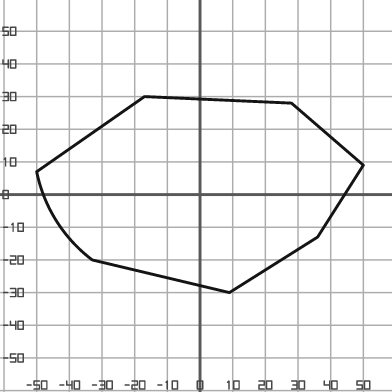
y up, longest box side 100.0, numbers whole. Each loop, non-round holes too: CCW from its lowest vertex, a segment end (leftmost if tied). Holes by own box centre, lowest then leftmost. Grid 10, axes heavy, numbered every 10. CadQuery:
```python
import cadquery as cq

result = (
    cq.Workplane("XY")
    .moveTo(9.0, -30.0)
    .lineTo(36.0, -13.0)
    .lineTo(50.0, 9.0)
    .lineTo(28.0, 28.0)
    .lineTo(-17.0, 30.0)
    .lineTo(-50.0, 7.0)
    .threePointArc((-44.0, -8.0), (-33.0, -20.0))
    .close()
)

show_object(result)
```